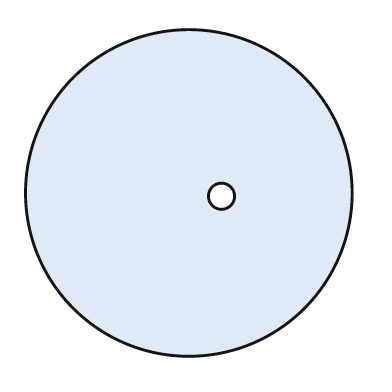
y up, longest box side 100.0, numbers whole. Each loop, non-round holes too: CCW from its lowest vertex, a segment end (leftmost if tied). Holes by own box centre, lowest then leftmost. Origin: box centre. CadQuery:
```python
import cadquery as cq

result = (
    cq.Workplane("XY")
    .moveTo(0.0, 0.0)
    .circle(50.0)
    .moveTo(10.0, -1.0)
    .circle(4.0)
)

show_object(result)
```